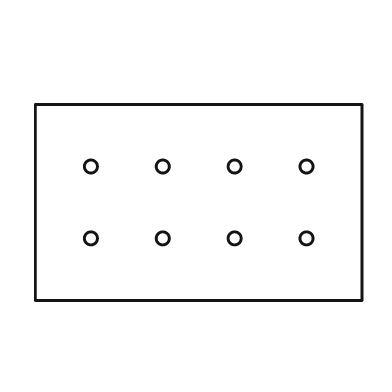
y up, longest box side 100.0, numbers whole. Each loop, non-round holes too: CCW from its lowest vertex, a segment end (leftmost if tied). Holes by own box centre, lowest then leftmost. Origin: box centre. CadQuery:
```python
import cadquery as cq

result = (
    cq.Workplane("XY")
    .moveTo(-50.0, -30.0)
    .lineTo(50.0, -30.0)
    .lineTo(50.0, 30.0)
    .lineTo(-50.0, 30.0)
    .close()
    .moveTo(-33.0, -11.0)
    .circle(2.0)
    .moveTo(-11.0, -11.0)
    .circle(2.0)
    .moveTo(11.0, -11.0)
    .circle(2.0)
    .moveTo(33.0, -11.0)
    .circle(2.0)
    .moveTo(-33.0, 11.0)
    .circle(2.0)
    .moveTo(-11.0, 11.0)
    .circle(2.0)
    .moveTo(11.0, 11.0)
    .circle(2.0)
    .moveTo(33.0, 11.0)
    .circle(2.0)
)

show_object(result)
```